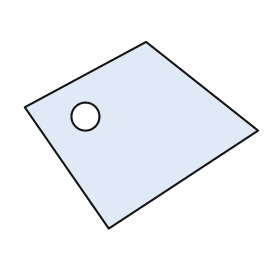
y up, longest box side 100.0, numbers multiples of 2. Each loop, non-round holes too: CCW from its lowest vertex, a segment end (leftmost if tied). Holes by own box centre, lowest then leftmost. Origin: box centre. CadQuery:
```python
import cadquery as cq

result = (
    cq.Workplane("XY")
    .moveTo(-14.0, -40.0)
    .lineTo(50.0, 2.0)
    .lineTo(2.0, 40.0)
    .lineTo(-50.0, 12.0)
    .close()
    .moveTo(-24.0, 8.0)
    .circle(6.0)
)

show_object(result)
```